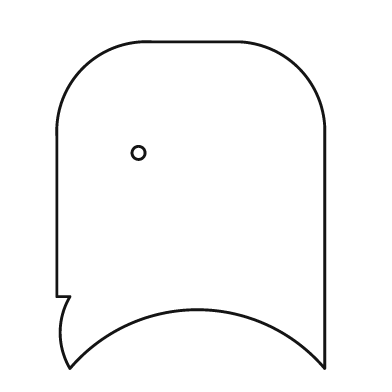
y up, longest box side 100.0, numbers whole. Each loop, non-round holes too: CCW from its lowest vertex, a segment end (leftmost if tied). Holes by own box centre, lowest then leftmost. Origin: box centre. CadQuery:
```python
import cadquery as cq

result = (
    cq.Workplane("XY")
    .moveTo(-37.0, -50.0)
    .threePointArc((2.0, -32.0), (41.0, -50.0))
    .lineTo(41.0, 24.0)
    .threePointArc((33.0, 42.0), (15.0, 50.0))
    .lineTo(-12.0, 50.0)
    .threePointArc((-33.0, 42.0), (-41.0, 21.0))
    .lineTo(-41.0, -28.0)
    .lineTo(-37.0, -28.0)
    .threePointArc((-40.0, -39.0), (-37.0, -50.0))
    .close()
    .moveTo(-16.0, 16.0)
    .circle(2.0)
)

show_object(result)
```